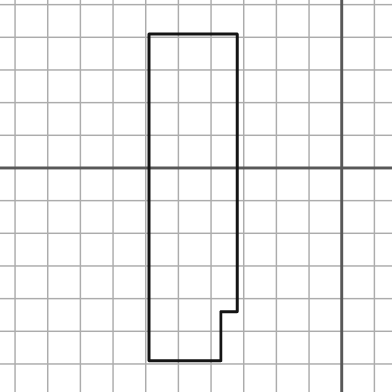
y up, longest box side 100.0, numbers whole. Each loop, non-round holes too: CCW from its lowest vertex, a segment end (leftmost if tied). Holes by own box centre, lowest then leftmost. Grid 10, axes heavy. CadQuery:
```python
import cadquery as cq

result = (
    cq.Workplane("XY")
    .moveTo(-59.0, -59.0)
    .lineTo(-37.0, -59.0)
    .lineTo(-37.0, -44.0)
    .lineTo(-32.0, -44.0)
    .lineTo(-32.0, 41.0)
    .lineTo(-59.0, 41.0)
    .close()
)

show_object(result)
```